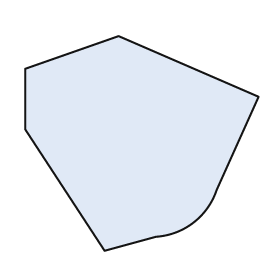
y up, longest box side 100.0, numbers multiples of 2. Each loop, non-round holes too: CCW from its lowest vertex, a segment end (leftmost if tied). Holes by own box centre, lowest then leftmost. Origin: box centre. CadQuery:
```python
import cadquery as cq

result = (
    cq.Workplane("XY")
    .moveTo(-16.0, -46.0)
    .lineTo(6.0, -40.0)
    .threePointArc((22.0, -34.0), (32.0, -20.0))
    .lineTo(50.0, 20.0)
    .lineTo(-10.0, 46.0)
    .lineTo(-50.0, 32.0)
    .lineTo(-50.0, 6.0)
    .close()
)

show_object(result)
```